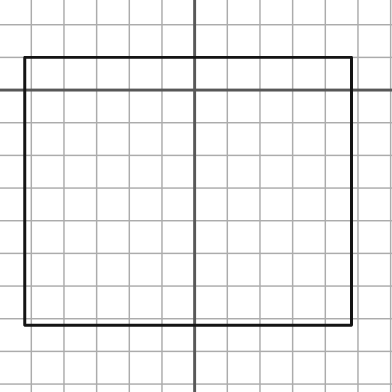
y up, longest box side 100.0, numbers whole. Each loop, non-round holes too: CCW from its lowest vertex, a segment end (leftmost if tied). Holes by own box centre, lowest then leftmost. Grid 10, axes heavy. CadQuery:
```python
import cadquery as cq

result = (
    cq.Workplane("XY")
    .moveTo(-52.0, -72.0)
    .lineTo(48.0, -72.0)
    .lineTo(48.0, 10.0)
    .lineTo(-52.0, 10.0)
    .close()
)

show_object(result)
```